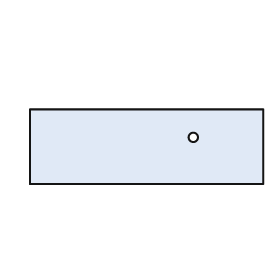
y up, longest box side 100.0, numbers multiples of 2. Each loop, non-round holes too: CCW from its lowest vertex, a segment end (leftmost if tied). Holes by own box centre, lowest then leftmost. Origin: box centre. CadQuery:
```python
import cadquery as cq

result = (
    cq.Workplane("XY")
    .moveTo(-50.0, -16.0)
    .lineTo(50.0, -16.0)
    .lineTo(50.0, 16.0)
    .lineTo(-50.0, 16.0)
    .close()
    .moveTo(20.0, 4.0)
    .circle(2.0)
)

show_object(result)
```